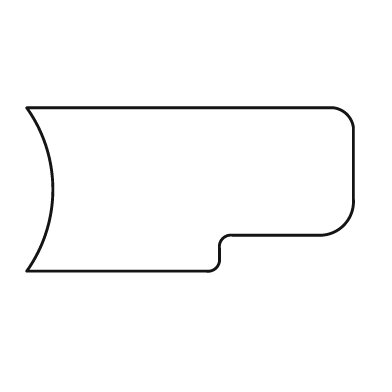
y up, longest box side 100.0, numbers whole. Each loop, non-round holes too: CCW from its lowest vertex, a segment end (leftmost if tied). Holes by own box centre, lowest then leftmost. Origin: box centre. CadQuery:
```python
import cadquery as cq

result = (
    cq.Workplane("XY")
    .moveTo(-50.0, -25.0)
    .lineTo(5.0, -25.0)
    .threePointArc((8.0, -24.0), (9.0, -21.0))
    .lineTo(9.0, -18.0)
    .threePointArc((10.0, -15.0), (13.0, -14.0))
    .lineTo(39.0, -14.0)
    .threePointArc((47.0, -11.0), (50.0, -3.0))
    .lineTo(50.0, 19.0)
    .threePointArc((48.0, 23.0), (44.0, 25.0))
    .lineTo(-50.0, 25.0)
    .threePointArc((-42.0, 0.0), (-50.0, -25.0))
    .close()
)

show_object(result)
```